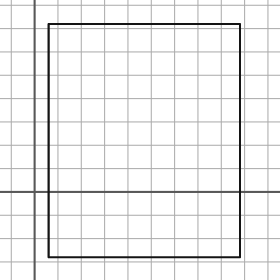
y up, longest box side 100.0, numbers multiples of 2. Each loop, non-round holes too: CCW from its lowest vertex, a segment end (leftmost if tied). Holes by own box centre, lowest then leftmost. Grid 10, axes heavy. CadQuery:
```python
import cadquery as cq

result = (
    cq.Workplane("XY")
    .moveTo(6.0, -28.0)
    .lineTo(88.0, -28.0)
    .lineTo(88.0, 72.0)
    .lineTo(6.0, 72.0)
    .close()
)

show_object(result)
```